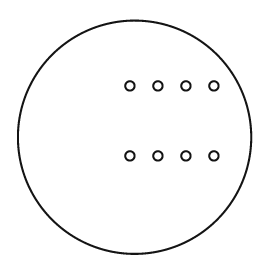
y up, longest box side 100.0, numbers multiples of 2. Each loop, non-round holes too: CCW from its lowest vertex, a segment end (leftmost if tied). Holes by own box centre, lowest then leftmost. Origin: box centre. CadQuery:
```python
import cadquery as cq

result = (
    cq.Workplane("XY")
    .moveTo(0.0, 0.0)
    .circle(50.0)
    .moveTo(-2.0, -8.0)
    .circle(2.0)
    .moveTo(10.0, -8.0)
    .circle(2.0)
    .moveTo(22.0, -8.0)
    .circle(2.0)
    .moveTo(34.0, -8.0)
    .circle(2.0)
    .moveTo(-2.0, 22.0)
    .circle(2.0)
    .moveTo(10.0, 22.0)
    .circle(2.0)
    .moveTo(22.0, 22.0)
    .circle(2.0)
    .moveTo(34.0, 22.0)
    .circle(2.0)
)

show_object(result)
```